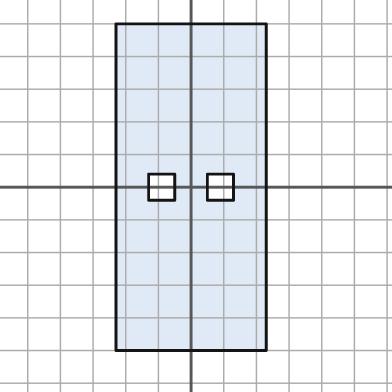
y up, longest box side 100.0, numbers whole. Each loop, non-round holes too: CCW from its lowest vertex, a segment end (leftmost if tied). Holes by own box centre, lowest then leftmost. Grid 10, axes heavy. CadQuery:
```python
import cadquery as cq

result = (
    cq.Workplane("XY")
    .moveTo(-23.0, -50.0)
    .lineTo(23.0, -50.0)
    .lineTo(23.0, 50.0)
    .lineTo(-23.0, 50.0)
    .close()
    .moveTo(-13.0, -4.0)
    .lineTo(-5.0, -4.0)
    .lineTo(-5.0, 4.0)
    .lineTo(-13.0, 4.0)
    .close()
    .moveTo(5.0, -4.0)
    .lineTo(13.0, -4.0)
    .lineTo(13.0, 4.0)
    .lineTo(5.0, 4.0)
    .close()
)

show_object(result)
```